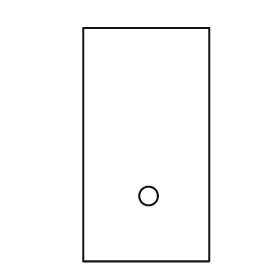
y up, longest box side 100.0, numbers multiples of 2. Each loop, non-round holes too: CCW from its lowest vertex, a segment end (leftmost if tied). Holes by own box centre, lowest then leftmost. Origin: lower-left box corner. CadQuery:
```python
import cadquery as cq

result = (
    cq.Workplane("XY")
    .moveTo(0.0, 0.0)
    .lineTo(54.0, 0.0)
    .lineTo(54.0, 100.0)
    .lineTo(0.0, 100.0)
    .close()
    .moveTo(28.0, 28.0)
    .circle(4.0)
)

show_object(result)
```